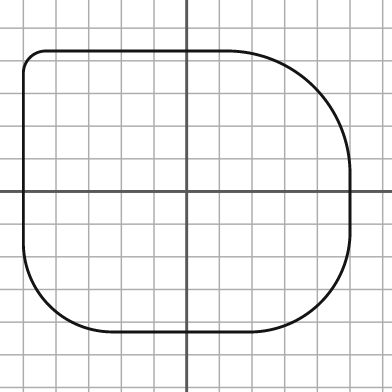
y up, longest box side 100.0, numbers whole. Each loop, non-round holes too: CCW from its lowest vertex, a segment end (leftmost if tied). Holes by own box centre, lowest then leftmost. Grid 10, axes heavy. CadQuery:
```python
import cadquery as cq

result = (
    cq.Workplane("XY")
    .moveTo(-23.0, -43.0)
    .lineTo(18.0, -43.0)
    .threePointArc((41.0, -34.0), (50.0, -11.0))
    .lineTo(50.0, 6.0)
    .threePointArc((39.0, 32.0), (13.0, 43.0))
    .lineTo(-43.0, 43.0)
    .threePointArc((-48.0, 41.0), (-50.0, 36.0))
    .lineTo(-50.0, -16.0)
    .threePointArc((-42.0, -35.0), (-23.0, -43.0))
    .close()
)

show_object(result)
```